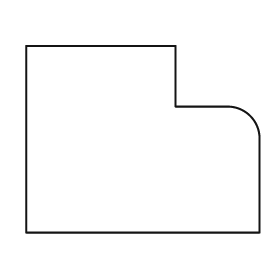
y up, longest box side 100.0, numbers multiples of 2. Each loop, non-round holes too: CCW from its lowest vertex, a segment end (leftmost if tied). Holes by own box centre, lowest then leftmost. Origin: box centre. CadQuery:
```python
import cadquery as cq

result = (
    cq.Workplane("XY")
    .moveTo(-50.0, -40.0)
    .lineTo(50.0, -40.0)
    .lineTo(50.0, 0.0)
    .threePointArc((46.0, 10.0), (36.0, 14.0))
    .lineTo(14.0, 14.0)
    .lineTo(14.0, 40.0)
    .lineTo(-50.0, 40.0)
    .close()
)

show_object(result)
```